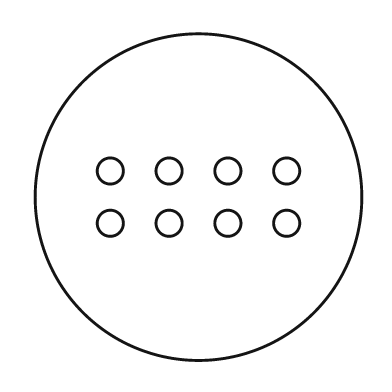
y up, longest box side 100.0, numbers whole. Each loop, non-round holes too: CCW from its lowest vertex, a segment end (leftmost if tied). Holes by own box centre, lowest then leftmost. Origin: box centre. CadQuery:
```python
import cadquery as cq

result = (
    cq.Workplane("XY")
    .moveTo(0.0, 0.0)
    .circle(50.0)
    .moveTo(-27.0, -8.0)
    .circle(4.0)
    .moveTo(-9.0, -8.0)
    .circle(4.0)
    .moveTo(9.0, -8.0)
    .circle(4.0)
    .moveTo(27.0, -8.0)
    .circle(4.0)
    .moveTo(-27.0, 8.0)
    .circle(4.0)
    .moveTo(-9.0, 8.0)
    .circle(4.0)
    .moveTo(9.0, 8.0)
    .circle(4.0)
    .moveTo(27.0, 8.0)
    .circle(4.0)
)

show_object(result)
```